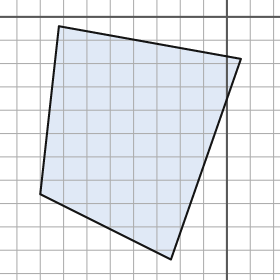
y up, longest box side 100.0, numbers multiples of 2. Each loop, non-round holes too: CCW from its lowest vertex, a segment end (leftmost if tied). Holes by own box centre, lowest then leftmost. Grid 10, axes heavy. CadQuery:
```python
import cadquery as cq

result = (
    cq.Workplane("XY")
    .moveTo(-24.0, -104.0)
    .lineTo(6.0, -18.0)
    .lineTo(-72.0, -4.0)
    .lineTo(-80.0, -76.0)
    .close()
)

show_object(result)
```